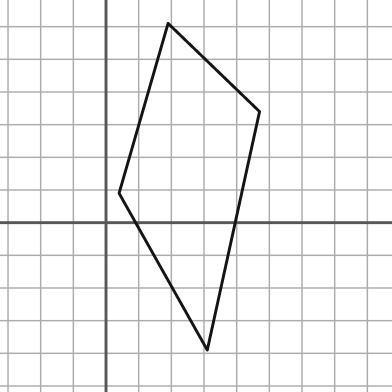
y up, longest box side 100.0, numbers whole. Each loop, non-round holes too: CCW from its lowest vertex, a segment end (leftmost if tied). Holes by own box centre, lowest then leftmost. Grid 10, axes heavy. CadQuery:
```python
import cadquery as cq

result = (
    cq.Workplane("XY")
    .moveTo(31.0, -39.0)
    .lineTo(47.0, 34.0)
    .lineTo(19.0, 61.0)
    .lineTo(4.0, 9.0)
    .close()
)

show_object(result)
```